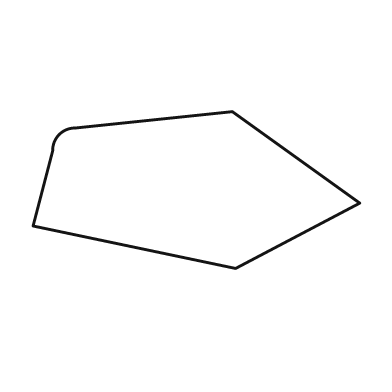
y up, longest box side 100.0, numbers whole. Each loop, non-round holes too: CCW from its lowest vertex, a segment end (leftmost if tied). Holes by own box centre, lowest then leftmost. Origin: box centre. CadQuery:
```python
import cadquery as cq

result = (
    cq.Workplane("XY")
    .moveTo(12.0, -24.0)
    .lineTo(50.0, -4.0)
    .lineTo(11.0, 24.0)
    .lineTo(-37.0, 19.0)
    .threePointArc((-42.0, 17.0), (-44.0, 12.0))
    .lineTo(-50.0, -11.0)
    .close()
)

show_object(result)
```